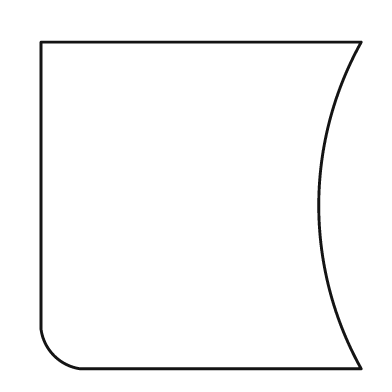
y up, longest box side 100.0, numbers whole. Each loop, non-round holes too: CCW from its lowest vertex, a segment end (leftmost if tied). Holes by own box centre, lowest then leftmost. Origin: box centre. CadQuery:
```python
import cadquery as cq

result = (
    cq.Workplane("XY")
    .moveTo(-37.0, -50.0)
    .lineTo(49.0, -50.0)
    .threePointArc((36.0, 0.0), (49.0, 50.0))
    .lineTo(-49.0, 50.0)
    .lineTo(-49.0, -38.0)
    .threePointArc((-45.0, -46.0), (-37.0, -50.0))
    .close()
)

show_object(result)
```